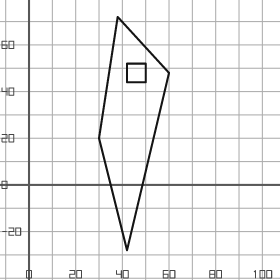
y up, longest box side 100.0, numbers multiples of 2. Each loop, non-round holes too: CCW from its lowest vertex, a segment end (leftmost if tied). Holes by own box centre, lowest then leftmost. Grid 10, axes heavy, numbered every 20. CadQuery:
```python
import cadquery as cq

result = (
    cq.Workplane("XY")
    .moveTo(42.0, -28.0)
    .lineTo(60.0, 48.0)
    .lineTo(38.0, 72.0)
    .lineTo(30.0, 20.0)
    .close()
    .moveTo(42.0, 44.0)
    .lineTo(50.0, 44.0)
    .lineTo(50.0, 52.0)
    .lineTo(42.0, 52.0)
    .close()
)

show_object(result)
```